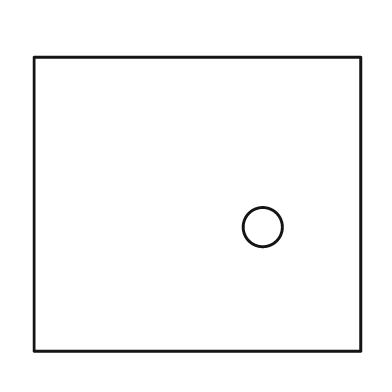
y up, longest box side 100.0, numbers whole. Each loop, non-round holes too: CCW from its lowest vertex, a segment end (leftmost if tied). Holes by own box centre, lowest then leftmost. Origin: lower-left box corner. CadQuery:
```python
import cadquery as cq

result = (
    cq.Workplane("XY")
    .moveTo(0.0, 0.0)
    .lineTo(100.0, 0.0)
    .lineTo(100.0, 90.0)
    .lineTo(0.0, 90.0)
    .close()
    .moveTo(70.0, 38.0)
    .circle(6.0)
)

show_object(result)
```